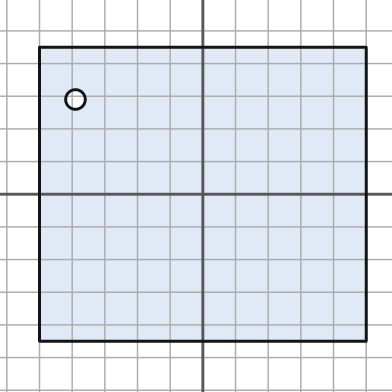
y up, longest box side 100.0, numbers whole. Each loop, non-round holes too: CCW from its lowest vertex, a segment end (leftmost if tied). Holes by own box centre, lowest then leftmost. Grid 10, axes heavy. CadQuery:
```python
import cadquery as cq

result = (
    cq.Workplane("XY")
    .moveTo(-50.0, -45.0)
    .lineTo(50.0, -45.0)
    .lineTo(50.0, 45.0)
    .lineTo(-50.0, 45.0)
    .close()
    .moveTo(-39.0, 29.0)
    .circle(3.0)
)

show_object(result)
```